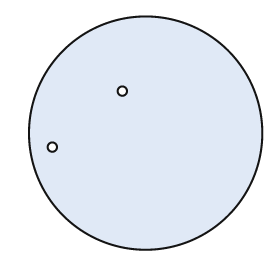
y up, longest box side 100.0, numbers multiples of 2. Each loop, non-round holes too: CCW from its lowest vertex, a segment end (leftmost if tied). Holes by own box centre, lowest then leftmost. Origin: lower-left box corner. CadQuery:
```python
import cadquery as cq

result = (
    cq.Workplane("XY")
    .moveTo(50.0, 50.0)
    .circle(50.0)
    .moveTo(10.0, 44.0)
    .circle(2.0)
    .moveTo(40.0, 68.0)
    .circle(2.0)
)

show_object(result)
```